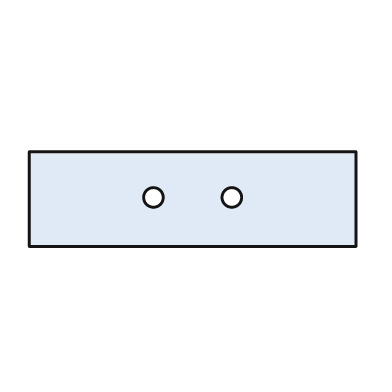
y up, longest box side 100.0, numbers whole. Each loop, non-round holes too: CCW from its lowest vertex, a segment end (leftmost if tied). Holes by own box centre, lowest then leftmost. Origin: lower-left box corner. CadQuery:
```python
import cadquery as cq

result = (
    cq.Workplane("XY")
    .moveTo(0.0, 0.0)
    .lineTo(100.0, 0.0)
    .lineTo(100.0, 29.0)
    .lineTo(0.0, 29.0)
    .close()
    .moveTo(38.0, 15.0)
    .circle(3.0)
    .moveTo(62.0, 15.0)
    .circle(3.0)
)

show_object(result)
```